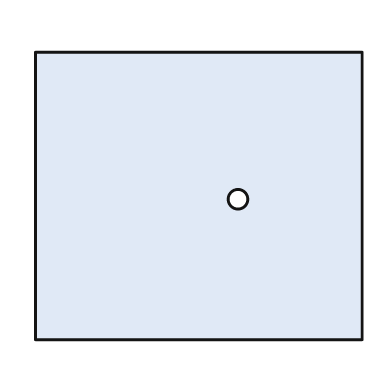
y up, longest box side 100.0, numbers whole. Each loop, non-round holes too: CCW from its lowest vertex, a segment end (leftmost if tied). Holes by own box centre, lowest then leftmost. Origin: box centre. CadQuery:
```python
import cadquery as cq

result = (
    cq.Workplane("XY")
    .moveTo(-50.0, -44.0)
    .lineTo(50.0, -44.0)
    .lineTo(50.0, 44.0)
    .lineTo(-50.0, 44.0)
    .close()
    .moveTo(12.0, -1.0)
    .circle(3.0)
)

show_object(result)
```